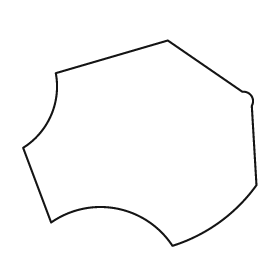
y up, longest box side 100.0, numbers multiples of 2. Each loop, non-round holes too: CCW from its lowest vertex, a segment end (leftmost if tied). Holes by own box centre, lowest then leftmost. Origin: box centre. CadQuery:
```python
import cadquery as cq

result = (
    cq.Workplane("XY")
    .moveTo(14.0, -44.0)
    .threePointArc((34.0, -34.0), (50.0, -18.0))
    .lineTo(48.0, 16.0)
    .threePointArc((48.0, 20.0), (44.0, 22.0))
    .lineTo(12.0, 44.0)
    .lineTo(-36.0, 30.0)
    .threePointArc((-38.0, 12.0), (-50.0, -2.0))
    .lineTo(-38.0, -34.0)
    .threePointArc((-10.0, -28.0), (14.0, -44.0))
    .close()
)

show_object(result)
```